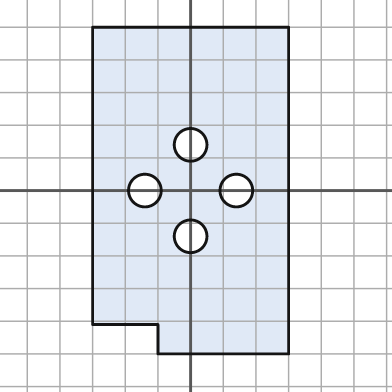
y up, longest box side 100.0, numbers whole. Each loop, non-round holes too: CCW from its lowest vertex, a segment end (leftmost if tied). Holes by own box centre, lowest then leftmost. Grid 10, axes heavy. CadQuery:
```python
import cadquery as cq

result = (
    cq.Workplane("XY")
    .moveTo(-10.0, -50.0)
    .lineTo(30.0, -50.0)
    .lineTo(30.0, 50.0)
    .lineTo(-30.0, 50.0)
    .lineTo(-30.0, -41.0)
    .lineTo(-10.0, -41.0)
    .close()
    .moveTo(0.0, -14.0)
    .circle(5.0)
    .moveTo(-14.0, 0.0)
    .circle(5.0)
    .moveTo(14.0, 0.0)
    .circle(5.0)
    .moveTo(0.0, 14.0)
    .circle(5.0)
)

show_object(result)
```